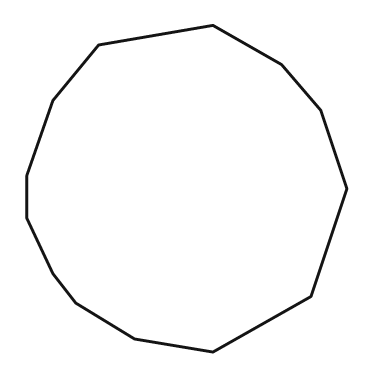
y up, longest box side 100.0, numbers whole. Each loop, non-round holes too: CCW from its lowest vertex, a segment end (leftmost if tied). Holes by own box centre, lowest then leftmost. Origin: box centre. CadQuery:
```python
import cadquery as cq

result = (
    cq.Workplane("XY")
    .moveTo(8.0, -50.0)
    .lineTo(38.0, -33.0)
    .lineTo(49.0, 0.0)
    .lineTo(41.0, 24.0)
    .lineTo(29.0, 38.0)
    .lineTo(8.0, 50.0)
    .lineTo(-27.0, 44.0)
    .lineTo(-41.0, 27.0)
    .lineTo(-49.0, 4.0)
    .lineTo(-49.0, -9.0)
    .lineTo(-41.0, -26.0)
    .lineTo(-34.0, -35.0)
    .lineTo(-16.0, -46.0)
    .close()
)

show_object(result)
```